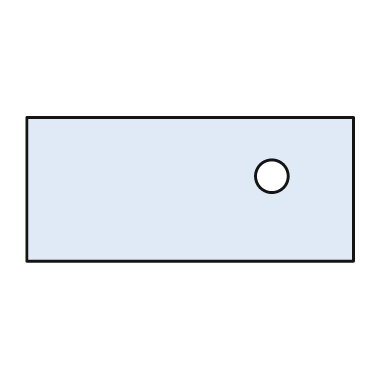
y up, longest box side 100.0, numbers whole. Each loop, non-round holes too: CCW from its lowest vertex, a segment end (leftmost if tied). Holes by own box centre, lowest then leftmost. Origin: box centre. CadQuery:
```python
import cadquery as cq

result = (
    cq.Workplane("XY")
    .moveTo(-50.0, -22.0)
    .lineTo(50.0, -22.0)
    .lineTo(50.0, 22.0)
    .lineTo(-50.0, 22.0)
    .close()
    .moveTo(25.0, 4.0)
    .circle(5.0)
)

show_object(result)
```